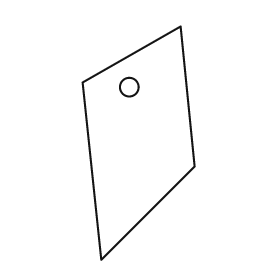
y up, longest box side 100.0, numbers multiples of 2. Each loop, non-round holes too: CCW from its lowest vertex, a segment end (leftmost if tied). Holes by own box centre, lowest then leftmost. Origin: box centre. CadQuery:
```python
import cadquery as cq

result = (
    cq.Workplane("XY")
    .moveTo(-16.0, -50.0)
    .lineTo(24.0, -10.0)
    .lineTo(18.0, 50.0)
    .lineTo(-24.0, 26.0)
    .close()
    .moveTo(-4.0, 24.0)
    .circle(4.0)
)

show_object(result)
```